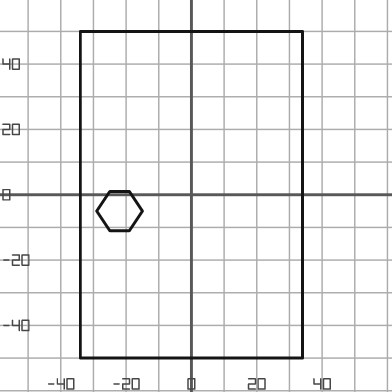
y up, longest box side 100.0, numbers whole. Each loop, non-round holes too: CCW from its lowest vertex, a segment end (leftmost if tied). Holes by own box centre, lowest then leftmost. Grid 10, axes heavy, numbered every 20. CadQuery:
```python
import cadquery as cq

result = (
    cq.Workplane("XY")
    .moveTo(-34.0, -50.0)
    .lineTo(34.0, -50.0)
    .lineTo(34.0, 50.0)
    .lineTo(-34.0, 50.0)
    .close()
    .moveTo(-25.0, -11.0)
    .lineTo(-19.0, -11.0)
    .lineTo(-15.0, -5.0)
    .lineTo(-19.0, 1.0)
    .lineTo(-25.0, 1.0)
    .lineTo(-29.0, -5.0)
    .close()
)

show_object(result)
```